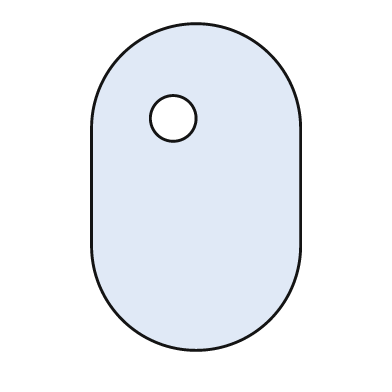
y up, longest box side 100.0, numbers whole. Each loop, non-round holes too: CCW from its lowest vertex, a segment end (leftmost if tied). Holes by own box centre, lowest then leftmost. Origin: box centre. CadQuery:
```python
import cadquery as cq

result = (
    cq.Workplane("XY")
    .moveTo(-32.0, -18.0)
    .threePointArc((0.0, -50.0), (32.0, -18.0))
    .lineTo(32.0, 18.0)
    .threePointArc((0.0, 50.0), (-32.0, 18.0))
    .close()
    .moveTo(-7.0, 21.0)
    .circle(7.0)
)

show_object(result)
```